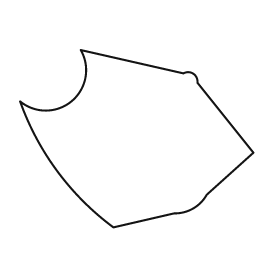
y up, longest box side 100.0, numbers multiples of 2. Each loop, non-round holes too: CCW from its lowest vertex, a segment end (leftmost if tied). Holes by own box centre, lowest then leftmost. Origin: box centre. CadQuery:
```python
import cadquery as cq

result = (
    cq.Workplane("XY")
    .moveTo(-10.0, -38.0)
    .lineTo(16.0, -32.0)
    .threePointArc((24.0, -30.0), (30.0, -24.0))
    .lineTo(50.0, -6.0)
    .lineTo(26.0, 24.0)
    .threePointArc((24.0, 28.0), (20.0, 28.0))
    .lineTo(-24.0, 38.0)
    .threePointArc((-28.0, 16.0), (-50.0, 16.0))
    .threePointArc((-34.0, -14.0), (-10.0, -38.0))
    .close()
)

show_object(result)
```